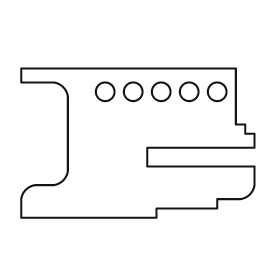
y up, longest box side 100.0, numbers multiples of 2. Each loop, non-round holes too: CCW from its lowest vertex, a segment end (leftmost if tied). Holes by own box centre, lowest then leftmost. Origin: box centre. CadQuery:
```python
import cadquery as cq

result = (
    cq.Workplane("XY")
    .moveTo(-50.0, -32.0)
    .lineTo(8.0, -32.0)
    .lineTo(8.0, -28.0)
    .lineTo(34.0, -28.0)
    .lineTo(34.0, -24.0)
    .lineTo(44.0, -24.0)
    .threePointArc((48.0, -22.0), (50.0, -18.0))
    .lineTo(50.0, -10.0)
    .lineTo(4.0, -10.0)
    .lineTo(4.0, -2.0)
    .lineTo(50.0, -2.0)
    .lineTo(50.0, 4.0)
    .lineTo(46.0, 4.0)
    .lineTo(46.0, 8.0)
    .lineTo(42.0, 8.0)
    .lineTo(42.0, 32.0)
    .lineTo(-50.0, 32.0)
    .lineTo(-50.0, 26.0)
    .lineTo(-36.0, 26.0)
    .threePointArc((-32.0, 24.0), (-30.0, 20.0))
    .lineTo(-30.0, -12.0)
    .threePointArc((-32.0, -16.0), (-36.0, -18.0))
    .lineTo(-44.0, -18.0)
    .threePointArc((-48.0, -20.0), (-50.0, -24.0))
    .close()
    .moveTo(-14.0, 22.0)
    .circle(4.0)
    .moveTo(-2.0, 22.0)
    .circle(4.0)
    .moveTo(10.0, 22.0)
    .circle(4.0)
    .moveTo(22.0, 22.0)
    .circle(4.0)
    .moveTo(34.0, 22.0)
    .circle(4.0)
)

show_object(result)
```